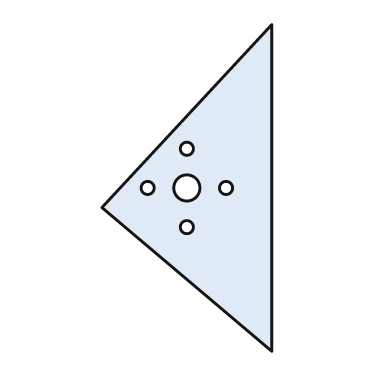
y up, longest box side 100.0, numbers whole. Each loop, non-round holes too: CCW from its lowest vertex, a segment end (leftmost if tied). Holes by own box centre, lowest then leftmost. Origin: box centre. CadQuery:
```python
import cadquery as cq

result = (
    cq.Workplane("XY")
    .moveTo(26.0, -50.0)
    .lineTo(26.0, 50.0)
    .lineTo(-26.0, -6.0)
    .close()
    .moveTo(0.0, -12.0)
    .circle(2.0)
    .moveTo(-12.0, 0.0)
    .circle(2.0)
    .moveTo(0.0, 0.0)
    .circle(4.0)
    .moveTo(12.0, 0.0)
    .circle(2.0)
    .moveTo(0.0, 12.0)
    .circle(2.0)
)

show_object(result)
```